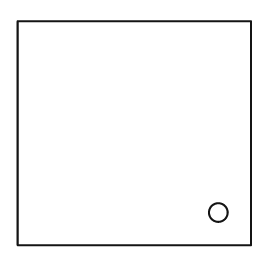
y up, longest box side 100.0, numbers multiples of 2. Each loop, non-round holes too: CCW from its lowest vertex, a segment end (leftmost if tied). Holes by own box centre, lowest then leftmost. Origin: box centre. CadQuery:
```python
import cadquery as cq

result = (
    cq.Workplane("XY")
    .moveTo(-50.0, -48.0)
    .lineTo(50.0, -48.0)
    .lineTo(50.0, 48.0)
    .lineTo(-50.0, 48.0)
    .close()
    .moveTo(36.0, -34.0)
    .circle(4.0)
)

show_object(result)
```